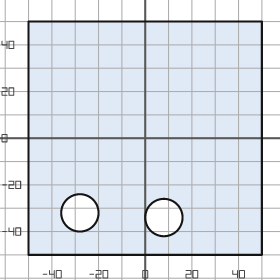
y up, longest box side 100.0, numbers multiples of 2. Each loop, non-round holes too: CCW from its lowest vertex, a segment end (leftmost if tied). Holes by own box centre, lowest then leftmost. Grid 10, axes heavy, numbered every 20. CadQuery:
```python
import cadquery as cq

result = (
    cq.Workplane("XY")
    .moveTo(-50.0, -50.0)
    .lineTo(50.0, -50.0)
    .lineTo(50.0, 50.0)
    .lineTo(-50.0, 50.0)
    .close()
    .moveTo(8.0, -34.0)
    .circle(8.0)
    .moveTo(-28.0, -32.0)
    .circle(8.0)
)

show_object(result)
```